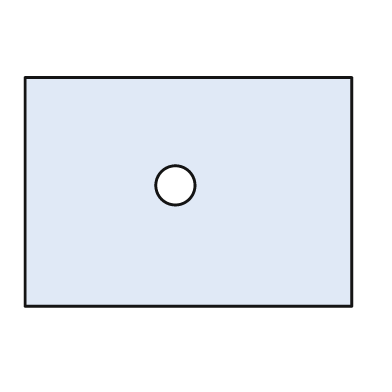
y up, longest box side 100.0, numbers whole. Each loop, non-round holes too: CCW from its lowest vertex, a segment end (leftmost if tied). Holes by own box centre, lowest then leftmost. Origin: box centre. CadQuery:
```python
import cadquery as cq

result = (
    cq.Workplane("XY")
    .moveTo(-50.0, -35.0)
    .lineTo(50.0, -35.0)
    .lineTo(50.0, 35.0)
    .lineTo(-50.0, 35.0)
    .close()
    .moveTo(-4.0, 2.0)
    .circle(6.0)
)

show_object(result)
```